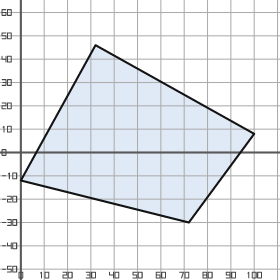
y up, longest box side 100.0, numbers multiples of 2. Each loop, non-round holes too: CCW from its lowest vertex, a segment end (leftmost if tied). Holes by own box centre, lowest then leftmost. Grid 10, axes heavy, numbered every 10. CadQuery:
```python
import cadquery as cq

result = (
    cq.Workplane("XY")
    .moveTo(72.0, -30.0)
    .lineTo(100.0, 8.0)
    .lineTo(32.0, 46.0)
    .lineTo(0.0, -12.0)
    .close()
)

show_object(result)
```